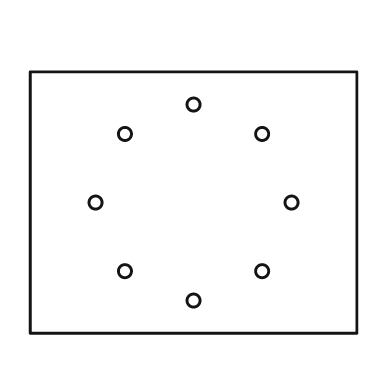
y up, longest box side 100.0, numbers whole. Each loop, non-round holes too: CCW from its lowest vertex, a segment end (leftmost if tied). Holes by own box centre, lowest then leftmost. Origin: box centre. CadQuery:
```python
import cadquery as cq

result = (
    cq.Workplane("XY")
    .moveTo(-50.0, -40.0)
    .lineTo(50.0, -40.0)
    .lineTo(50.0, 40.0)
    .lineTo(-50.0, 40.0)
    .close()
    .moveTo(0.0, -30.0)
    .circle(2.0)
    .moveTo(-21.0, -21.0)
    .circle(2.0)
    .moveTo(21.0, -21.0)
    .circle(2.0)
    .moveTo(-30.0, 0.0)
    .circle(2.0)
    .moveTo(30.0, 0.0)
    .circle(2.0)
    .moveTo(-21.0, 21.0)
    .circle(2.0)
    .moveTo(21.0, 21.0)
    .circle(2.0)
    .moveTo(0.0, 30.0)
    .circle(2.0)
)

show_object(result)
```